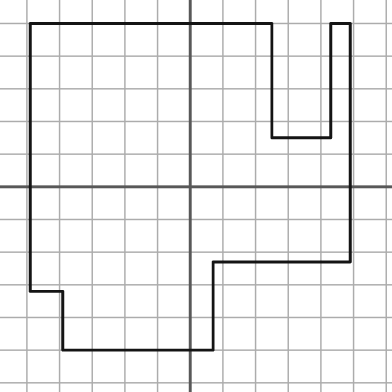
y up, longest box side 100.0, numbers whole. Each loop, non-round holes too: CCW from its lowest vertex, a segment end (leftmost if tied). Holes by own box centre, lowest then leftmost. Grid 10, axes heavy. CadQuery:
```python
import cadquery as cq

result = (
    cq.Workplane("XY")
    .moveTo(-39.0, -50.0)
    .lineTo(7.0, -50.0)
    .lineTo(7.0, -23.0)
    .lineTo(49.0, -23.0)
    .lineTo(49.0, 50.0)
    .lineTo(43.0, 50.0)
    .lineTo(43.0, 15.0)
    .lineTo(25.0, 15.0)
    .lineTo(25.0, 50.0)
    .lineTo(-49.0, 50.0)
    .lineTo(-49.0, -32.0)
    .lineTo(-39.0, -32.0)
    .close()
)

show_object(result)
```